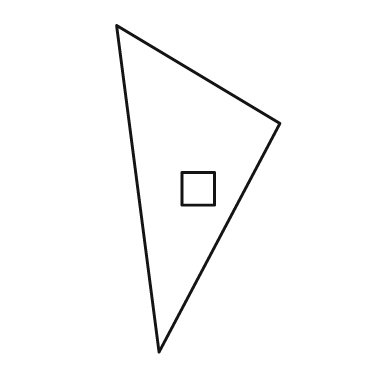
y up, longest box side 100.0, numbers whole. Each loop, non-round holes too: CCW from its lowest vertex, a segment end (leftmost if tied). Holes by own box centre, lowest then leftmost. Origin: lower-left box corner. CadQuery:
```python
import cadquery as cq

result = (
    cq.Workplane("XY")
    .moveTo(13.0, 0.0)
    .lineTo(50.0, 70.0)
    .lineTo(0.0, 100.0)
    .close()
    .moveTo(20.0, 45.0)
    .lineTo(30.0, 45.0)
    .lineTo(30.0, 55.0)
    .lineTo(20.0, 55.0)
    .close()
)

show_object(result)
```